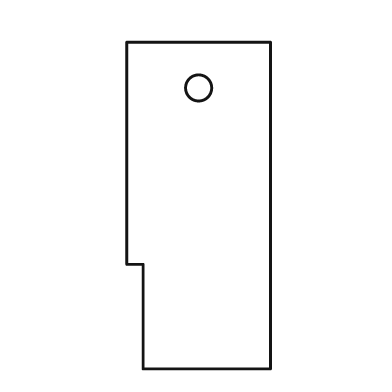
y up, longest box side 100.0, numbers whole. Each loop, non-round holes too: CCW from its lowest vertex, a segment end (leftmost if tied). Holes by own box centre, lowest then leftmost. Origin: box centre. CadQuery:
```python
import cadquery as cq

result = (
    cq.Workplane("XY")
    .moveTo(-17.0, -50.0)
    .lineTo(22.0, -50.0)
    .lineTo(22.0, 50.0)
    .lineTo(-22.0, 50.0)
    .lineTo(-22.0, -18.0)
    .lineTo(-17.0, -18.0)
    .close()
    .moveTo(0.0, 36.0)
    .circle(4.0)
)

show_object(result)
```